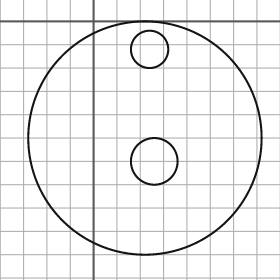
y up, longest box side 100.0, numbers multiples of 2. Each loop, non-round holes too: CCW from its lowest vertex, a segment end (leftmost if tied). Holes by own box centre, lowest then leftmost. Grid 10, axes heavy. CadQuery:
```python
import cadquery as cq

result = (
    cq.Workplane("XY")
    .moveTo(22.0, -50.0)
    .circle(50.0)
    .moveTo(26.0, -60.0)
    .circle(10.0)
    .moveTo(24.0, -12.0)
    .circle(8.0)
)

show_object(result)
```